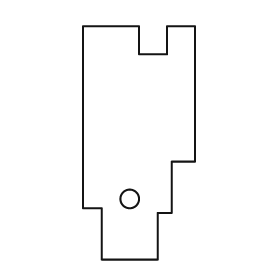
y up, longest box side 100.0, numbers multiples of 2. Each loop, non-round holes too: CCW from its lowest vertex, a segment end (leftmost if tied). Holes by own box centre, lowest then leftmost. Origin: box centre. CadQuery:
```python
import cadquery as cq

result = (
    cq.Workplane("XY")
    .moveTo(-16.0, -50.0)
    .lineTo(8.0, -50.0)
    .lineTo(8.0, -30.0)
    .lineTo(14.0, -30.0)
    .lineTo(14.0, -8.0)
    .lineTo(24.0, -8.0)
    .lineTo(24.0, 50.0)
    .lineTo(12.0, 50.0)
    .lineTo(12.0, 38.0)
    .lineTo(0.0, 38.0)
    .lineTo(0.0, 50.0)
    .lineTo(-24.0, 50.0)
    .lineTo(-24.0, -28.0)
    .lineTo(-16.0, -28.0)
    .close()
    .moveTo(-4.0, -24.0)
    .circle(4.0)
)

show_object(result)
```